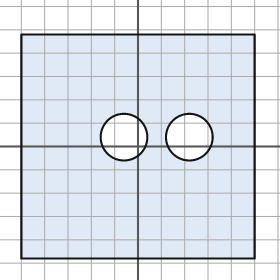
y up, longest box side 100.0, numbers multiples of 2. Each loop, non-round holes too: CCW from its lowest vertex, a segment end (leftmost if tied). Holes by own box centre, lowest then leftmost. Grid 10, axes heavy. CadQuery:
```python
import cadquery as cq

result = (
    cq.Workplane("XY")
    .moveTo(-50.0, -48.0)
    .lineTo(50.0, -48.0)
    .lineTo(50.0, 48.0)
    .lineTo(-50.0, 48.0)
    .close()
    .moveTo(-6.0, 4.0)
    .circle(10.0)
    .moveTo(22.0, 4.0)
    .circle(10.0)
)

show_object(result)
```